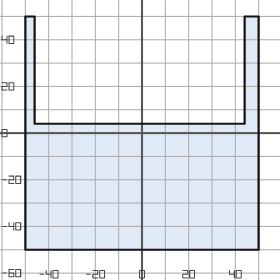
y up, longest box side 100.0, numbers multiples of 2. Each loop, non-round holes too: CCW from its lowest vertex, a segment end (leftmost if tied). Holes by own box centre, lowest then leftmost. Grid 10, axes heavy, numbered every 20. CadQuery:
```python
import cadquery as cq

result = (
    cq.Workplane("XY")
    .moveTo(-50.0, -50.0)
    .lineTo(50.0, -50.0)
    .lineTo(50.0, 50.0)
    .lineTo(44.0, 50.0)
    .lineTo(44.0, 4.0)
    .lineTo(-46.0, 4.0)
    .lineTo(-46.0, 50.0)
    .lineTo(-50.0, 50.0)
    .close()
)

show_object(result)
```